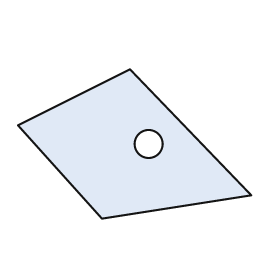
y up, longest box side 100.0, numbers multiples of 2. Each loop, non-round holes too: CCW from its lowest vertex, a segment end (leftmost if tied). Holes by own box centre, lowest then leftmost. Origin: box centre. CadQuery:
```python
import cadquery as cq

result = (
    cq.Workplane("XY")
    .moveTo(-14.0, -32.0)
    .lineTo(50.0, -22.0)
    .lineTo(-2.0, 32.0)
    .lineTo(-50.0, 8.0)
    .close()
    .moveTo(6.0, 0.0)
    .circle(6.0)
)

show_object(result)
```